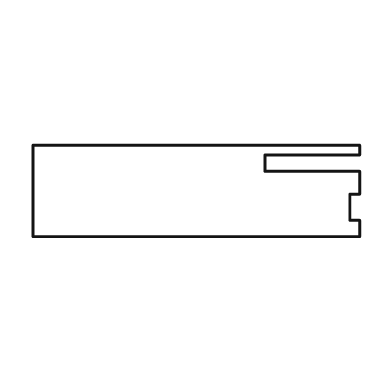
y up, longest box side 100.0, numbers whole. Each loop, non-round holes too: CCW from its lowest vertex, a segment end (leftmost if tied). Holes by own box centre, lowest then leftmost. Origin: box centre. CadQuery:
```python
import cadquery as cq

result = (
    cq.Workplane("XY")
    .moveTo(-50.0, -14.0)
    .lineTo(50.0, -14.0)
    .lineTo(50.0, -9.0)
    .lineTo(47.0, -9.0)
    .lineTo(47.0, -1.0)
    .lineTo(50.0, -1.0)
    .lineTo(50.0, 6.0)
    .lineTo(21.0, 6.0)
    .lineTo(21.0, 11.0)
    .lineTo(50.0, 11.0)
    .lineTo(50.0, 14.0)
    .lineTo(-50.0, 14.0)
    .close()
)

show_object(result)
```